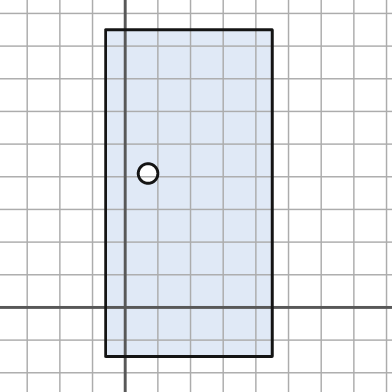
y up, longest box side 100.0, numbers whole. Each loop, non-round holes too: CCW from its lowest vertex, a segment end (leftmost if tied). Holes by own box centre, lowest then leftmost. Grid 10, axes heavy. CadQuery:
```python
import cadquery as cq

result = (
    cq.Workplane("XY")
    .moveTo(-6.0, -15.0)
    .lineTo(45.0, -15.0)
    .lineTo(45.0, 85.0)
    .lineTo(-6.0, 85.0)
    .close()
    .moveTo(7.0, 41.0)
    .circle(3.0)
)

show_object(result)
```